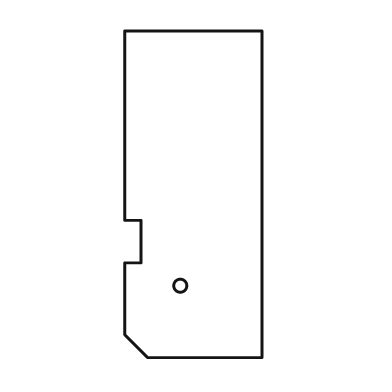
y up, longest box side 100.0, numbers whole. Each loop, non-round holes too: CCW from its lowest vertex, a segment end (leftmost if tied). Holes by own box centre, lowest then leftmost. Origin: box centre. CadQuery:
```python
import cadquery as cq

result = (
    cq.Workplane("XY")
    .moveTo(-14.0, -50.0)
    .lineTo(21.0, -50.0)
    .lineTo(21.0, 50.0)
    .lineTo(-21.0, 50.0)
    .lineTo(-21.0, -8.0)
    .lineTo(-16.0, -8.0)
    .lineTo(-16.0, -21.0)
    .lineTo(-21.0, -21.0)
    .lineTo(-21.0, -43.0)
    .close()
    .moveTo(-4.0, -28.0)
    .circle(2.0)
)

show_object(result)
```